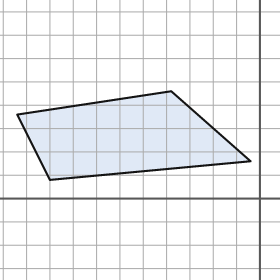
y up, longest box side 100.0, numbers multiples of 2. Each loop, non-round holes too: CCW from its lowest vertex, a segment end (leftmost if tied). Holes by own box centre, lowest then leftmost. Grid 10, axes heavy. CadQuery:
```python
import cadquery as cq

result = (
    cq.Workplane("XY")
    .moveTo(-90.0, 8.0)
    .lineTo(-4.0, 16.0)
    .lineTo(-38.0, 46.0)
    .lineTo(-104.0, 36.0)
    .close()
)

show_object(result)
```